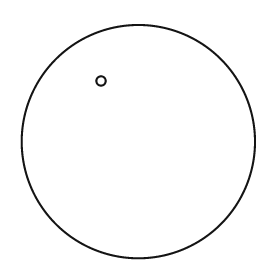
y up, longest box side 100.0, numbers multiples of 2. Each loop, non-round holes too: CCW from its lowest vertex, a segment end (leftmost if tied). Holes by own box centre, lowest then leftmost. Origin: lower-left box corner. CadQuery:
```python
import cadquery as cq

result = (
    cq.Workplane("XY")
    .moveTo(50.0, 50.0)
    .circle(50.0)
    .moveTo(34.0, 76.0)
    .circle(2.0)
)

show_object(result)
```